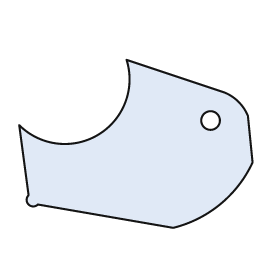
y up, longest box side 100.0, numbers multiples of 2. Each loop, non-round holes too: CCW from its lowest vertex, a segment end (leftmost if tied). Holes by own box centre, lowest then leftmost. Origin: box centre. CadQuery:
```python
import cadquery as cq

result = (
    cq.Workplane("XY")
    .moveTo(16.0, -36.0)
    .threePointArc((36.0, -26.0), (50.0, -8.0))
    .lineTo(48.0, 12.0)
    .threePointArc((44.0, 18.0), (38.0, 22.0))
    .lineTo(-4.0, 36.0)
    .threePointArc((-16.0, 4.0), (-50.0, 8.0))
    .lineTo(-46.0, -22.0)
    .threePointArc((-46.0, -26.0), (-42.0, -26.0))
    .close()
    .moveTo(32.0, 10.0)
    .circle(4.0)
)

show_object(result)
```